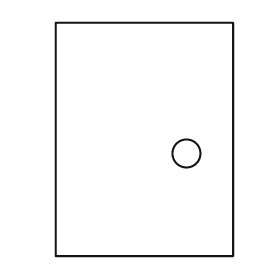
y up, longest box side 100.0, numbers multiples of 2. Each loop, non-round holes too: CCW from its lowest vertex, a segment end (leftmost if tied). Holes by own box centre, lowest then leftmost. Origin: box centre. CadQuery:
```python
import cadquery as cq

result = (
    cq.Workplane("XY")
    .moveTo(-38.0, -50.0)
    .lineTo(38.0, -50.0)
    .lineTo(38.0, 50.0)
    .lineTo(-38.0, 50.0)
    .close()
    .moveTo(18.0, -6.0)
    .circle(6.0)
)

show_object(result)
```